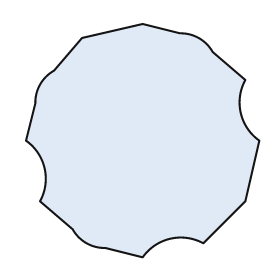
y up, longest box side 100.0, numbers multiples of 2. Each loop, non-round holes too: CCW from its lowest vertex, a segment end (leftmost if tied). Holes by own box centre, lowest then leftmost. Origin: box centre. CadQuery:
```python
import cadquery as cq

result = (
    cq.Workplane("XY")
    .moveTo(0.0, -50.0)
    .threePointArc((12.0, -42.0), (26.0, -44.0))
    .lineTo(44.0, -26.0)
    .lineTo(50.0, 0.0)
    .threePointArc((42.0, 12.0), (44.0, 26.0))
    .lineTo(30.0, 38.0)
    .threePointArc((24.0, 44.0), (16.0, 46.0))
    .lineTo(0.0, 50.0)
    .lineTo(-26.0, 44.0)
    .lineTo(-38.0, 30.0)
    .threePointArc((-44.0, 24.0), (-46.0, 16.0))
    .lineTo(-50.0, 0.0)
    .threePointArc((-42.0, -12.0), (-44.0, -26.0))
    .lineTo(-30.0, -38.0)
    .threePointArc((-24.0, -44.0), (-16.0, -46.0))
    .close()
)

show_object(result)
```